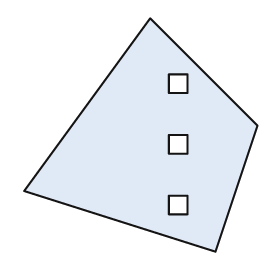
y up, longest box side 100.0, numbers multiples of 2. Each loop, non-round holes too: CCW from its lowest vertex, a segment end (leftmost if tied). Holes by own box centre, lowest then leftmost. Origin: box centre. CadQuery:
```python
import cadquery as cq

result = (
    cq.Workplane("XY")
    .moveTo(32.0, -50.0)
    .lineTo(50.0, 4.0)
    .lineTo(4.0, 50.0)
    .lineTo(-50.0, -24.0)
    .close()
    .moveTo(12.0, -34.0)
    .lineTo(20.0, -34.0)
    .lineTo(20.0, -26.0)
    .lineTo(12.0, -26.0)
    .close()
    .moveTo(12.0, -8.0)
    .lineTo(20.0, -8.0)
    .lineTo(20.0, 0.0)
    .lineTo(12.0, 0.0)
    .close()
    .moveTo(12.0, 18.0)
    .lineTo(20.0, 18.0)
    .lineTo(20.0, 26.0)
    .lineTo(12.0, 26.0)
    .close()
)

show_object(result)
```